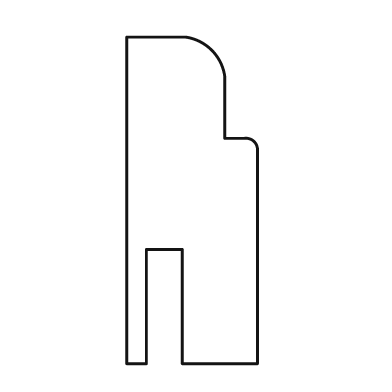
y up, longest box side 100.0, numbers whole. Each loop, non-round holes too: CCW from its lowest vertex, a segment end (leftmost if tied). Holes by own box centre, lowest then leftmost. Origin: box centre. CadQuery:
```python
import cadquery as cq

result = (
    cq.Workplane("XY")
    .moveTo(-20.0, -50.0)
    .lineTo(-14.0, -50.0)
    .lineTo(-14.0, -15.0)
    .lineTo(-3.0, -15.0)
    .lineTo(-3.0, -50.0)
    .lineTo(20.0, -50.0)
    .lineTo(20.0, 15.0)
    .threePointArc((19.0, 18.0), (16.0, 19.0))
    .lineTo(10.0, 19.0)
    .lineTo(10.0, 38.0)
    .threePointArc((6.0, 46.0), (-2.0, 50.0))
    .lineTo(-20.0, 50.0)
    .close()
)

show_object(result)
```